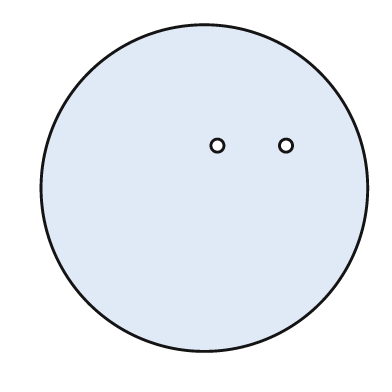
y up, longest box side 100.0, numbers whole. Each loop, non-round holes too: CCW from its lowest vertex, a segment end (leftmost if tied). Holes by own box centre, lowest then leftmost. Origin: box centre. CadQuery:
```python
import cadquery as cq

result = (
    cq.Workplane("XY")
    .moveTo(0.0, 0.0)
    .circle(50.0)
    .moveTo(4.0, 13.0)
    .circle(2.0)
    .moveTo(25.0, 13.0)
    .circle(2.0)
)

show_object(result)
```